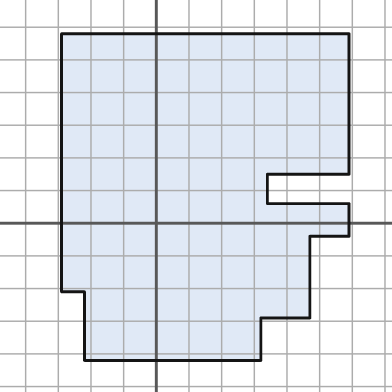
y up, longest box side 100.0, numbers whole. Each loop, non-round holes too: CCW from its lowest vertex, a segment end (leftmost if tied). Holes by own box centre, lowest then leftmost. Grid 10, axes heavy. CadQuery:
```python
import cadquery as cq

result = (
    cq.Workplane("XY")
    .moveTo(-22.0, -42.0)
    .lineTo(32.0, -42.0)
    .lineTo(32.0, -29.0)
    .lineTo(47.0, -29.0)
    .lineTo(47.0, -4.0)
    .lineTo(59.0, -4.0)
    .lineTo(59.0, 6.0)
    .lineTo(34.0, 6.0)
    .lineTo(34.0, 15.0)
    .lineTo(59.0, 15.0)
    .lineTo(59.0, 58.0)
    .lineTo(-29.0, 58.0)
    .lineTo(-29.0, -21.0)
    .lineTo(-22.0, -21.0)
    .close()
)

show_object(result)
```